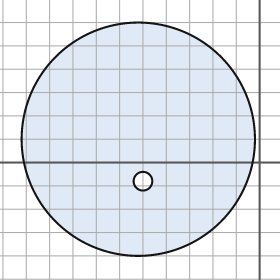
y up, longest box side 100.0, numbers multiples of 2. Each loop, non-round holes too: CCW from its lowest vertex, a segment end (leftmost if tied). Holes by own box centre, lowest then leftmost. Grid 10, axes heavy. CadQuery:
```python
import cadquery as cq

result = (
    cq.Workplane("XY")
    .moveTo(-52.0, 10.0)
    .circle(50.0)
    .moveTo(-50.0, -8.0)
    .circle(4.0)
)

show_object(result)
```